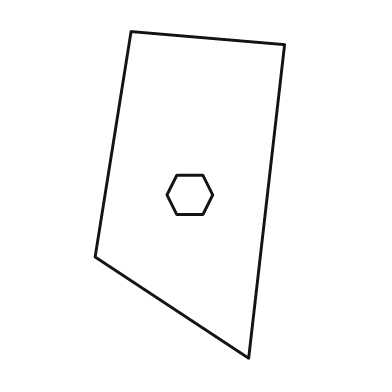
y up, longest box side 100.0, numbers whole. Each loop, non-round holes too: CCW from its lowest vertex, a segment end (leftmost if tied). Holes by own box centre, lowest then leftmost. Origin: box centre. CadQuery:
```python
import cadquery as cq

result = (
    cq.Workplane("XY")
    .moveTo(18.0, -50.0)
    .lineTo(29.0, 46.0)
    .lineTo(-18.0, 50.0)
    .lineTo(-29.0, -19.0)
    .close()
    .moveTo(-4.0, -6.0)
    .lineTo(4.0, -6.0)
    .lineTo(7.0, 0.0)
    .lineTo(4.0, 6.0)
    .lineTo(-4.0, 6.0)
    .lineTo(-7.0, 0.0)
    .close()
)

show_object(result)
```